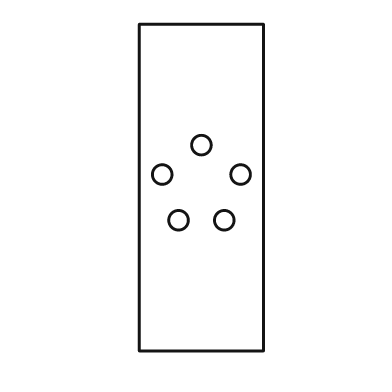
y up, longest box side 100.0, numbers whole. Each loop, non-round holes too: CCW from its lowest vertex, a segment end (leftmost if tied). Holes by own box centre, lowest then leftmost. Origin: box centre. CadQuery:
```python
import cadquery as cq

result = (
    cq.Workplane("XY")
    .moveTo(-19.0, -50.0)
    .lineTo(19.0, -50.0)
    .lineTo(19.0, 50.0)
    .lineTo(-19.0, 50.0)
    .close()
    .moveTo(-7.0, -10.0)
    .circle(3.0)
    .moveTo(7.0, -10.0)
    .circle(3.0)
    .moveTo(-12.0, 4.0)
    .circle(3.0)
    .moveTo(12.0, 4.0)
    .circle(3.0)
    .moveTo(0.0, 13.0)
    .circle(3.0)
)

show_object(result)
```